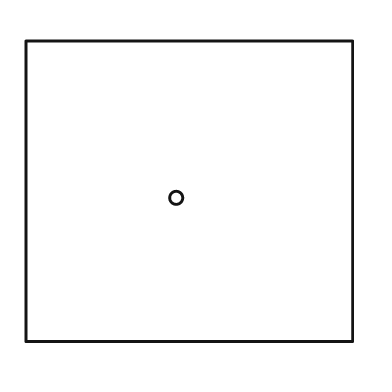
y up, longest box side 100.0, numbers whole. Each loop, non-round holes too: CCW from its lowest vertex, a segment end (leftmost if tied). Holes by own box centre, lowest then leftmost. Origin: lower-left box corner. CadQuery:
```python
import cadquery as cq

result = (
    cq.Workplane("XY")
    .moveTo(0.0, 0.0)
    .lineTo(100.0, 0.0)
    .lineTo(100.0, 92.0)
    .lineTo(0.0, 92.0)
    .close()
    .moveTo(46.0, 44.0)
    .circle(2.0)
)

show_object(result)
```